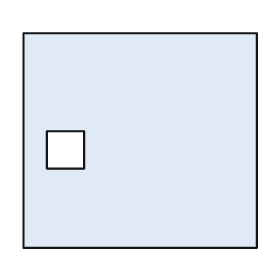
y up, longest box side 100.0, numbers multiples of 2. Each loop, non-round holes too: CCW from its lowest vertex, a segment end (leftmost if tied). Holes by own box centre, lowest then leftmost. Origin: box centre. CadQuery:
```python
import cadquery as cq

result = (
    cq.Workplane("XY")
    .moveTo(-50.0, -46.0)
    .lineTo(50.0, -46.0)
    .lineTo(50.0, 46.0)
    .lineTo(-50.0, 46.0)
    .close()
    .moveTo(-40.0, -12.0)
    .lineTo(-24.0, -12.0)
    .lineTo(-24.0, 4.0)
    .lineTo(-40.0, 4.0)
    .close()
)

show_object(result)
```